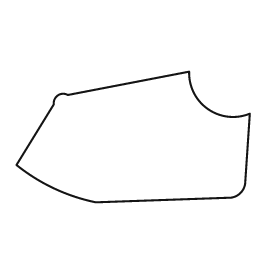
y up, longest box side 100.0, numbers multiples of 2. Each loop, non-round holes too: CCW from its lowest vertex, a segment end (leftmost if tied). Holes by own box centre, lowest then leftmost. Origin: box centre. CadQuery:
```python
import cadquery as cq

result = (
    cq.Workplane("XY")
    .moveTo(-16.0, -28.0)
    .lineTo(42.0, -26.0)
    .threePointArc((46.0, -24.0), (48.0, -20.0))
    .lineTo(50.0, 10.0)
    .threePointArc((32.0, 12.0), (24.0, 28.0))
    .lineTo(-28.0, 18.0)
    .threePointArc((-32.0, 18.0), (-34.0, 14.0))
    .lineTo(-50.0, -12.0)
    .threePointArc((-34.0, -22.0), (-16.0, -28.0))
    .close()
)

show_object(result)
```